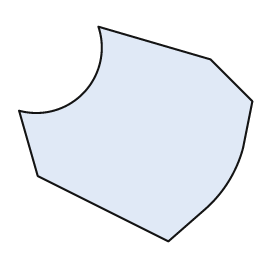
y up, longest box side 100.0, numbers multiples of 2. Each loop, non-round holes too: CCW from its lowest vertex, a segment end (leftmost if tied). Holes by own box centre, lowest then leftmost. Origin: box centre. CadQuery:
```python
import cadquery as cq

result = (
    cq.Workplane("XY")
    .moveTo(14.0, -46.0)
    .lineTo(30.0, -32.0)
    .threePointArc((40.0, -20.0), (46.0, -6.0))
    .lineTo(50.0, 14.0)
    .lineTo(32.0, 32.0)
    .lineTo(-16.0, 46.0)
    .threePointArc((-22.0, 18.0), (-50.0, 10.0))
    .lineTo(-42.0, -18.0)
    .close()
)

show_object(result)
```